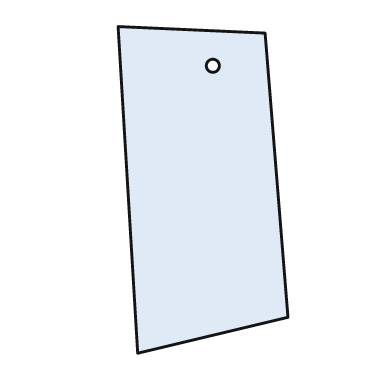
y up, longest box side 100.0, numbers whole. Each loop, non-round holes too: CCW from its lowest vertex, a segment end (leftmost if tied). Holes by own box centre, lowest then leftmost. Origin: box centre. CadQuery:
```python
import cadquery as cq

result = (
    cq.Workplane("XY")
    .moveTo(-20.0, -50.0)
    .lineTo(26.0, -39.0)
    .lineTo(19.0, 48.0)
    .lineTo(-26.0, 50.0)
    .close()
    .moveTo(3.0, 38.0)
    .circle(2.0)
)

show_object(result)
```